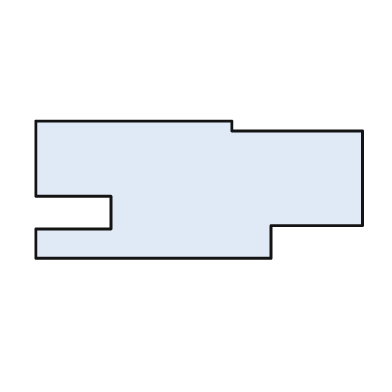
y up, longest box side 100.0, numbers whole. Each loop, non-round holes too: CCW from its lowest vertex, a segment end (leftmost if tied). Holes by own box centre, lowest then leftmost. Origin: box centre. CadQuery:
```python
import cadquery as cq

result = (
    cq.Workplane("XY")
    .moveTo(-50.0, -21.0)
    .lineTo(22.0, -21.0)
    .lineTo(22.0, -11.0)
    .lineTo(50.0, -11.0)
    .lineTo(50.0, 18.0)
    .lineTo(10.0, 18.0)
    .lineTo(10.0, 21.0)
    .lineTo(-50.0, 21.0)
    .lineTo(-50.0, -2.0)
    .lineTo(-27.0, -2.0)
    .lineTo(-27.0, -12.0)
    .lineTo(-50.0, -12.0)
    .close()
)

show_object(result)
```